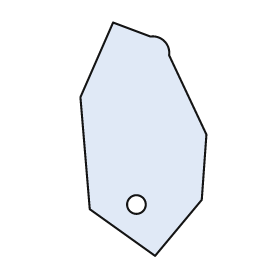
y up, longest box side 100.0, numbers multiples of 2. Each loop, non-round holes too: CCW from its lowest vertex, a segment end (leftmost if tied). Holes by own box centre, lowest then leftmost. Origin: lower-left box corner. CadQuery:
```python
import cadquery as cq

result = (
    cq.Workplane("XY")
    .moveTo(32.0, 0.0)
    .lineTo(52.0, 24.0)
    .lineTo(54.0, 52.0)
    .lineTo(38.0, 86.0)
    .threePointArc((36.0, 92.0), (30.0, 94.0))
    .lineTo(14.0, 100.0)
    .lineTo(0.0, 68.0)
    .lineTo(4.0, 20.0)
    .close()
    .moveTo(24.0, 22.0)
    .circle(4.0)
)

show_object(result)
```